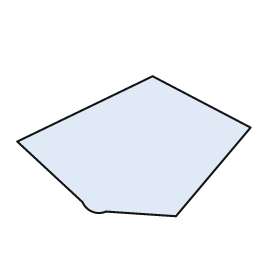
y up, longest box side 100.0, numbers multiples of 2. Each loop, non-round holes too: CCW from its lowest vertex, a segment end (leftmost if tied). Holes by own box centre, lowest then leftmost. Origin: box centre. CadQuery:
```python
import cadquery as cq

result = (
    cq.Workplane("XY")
    .moveTo(18.0, -30.0)
    .lineTo(50.0, 8.0)
    .lineTo(8.0, 30.0)
    .lineTo(-50.0, 2.0)
    .lineTo(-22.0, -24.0)
    .threePointArc((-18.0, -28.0), (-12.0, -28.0))
    .close()
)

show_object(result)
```